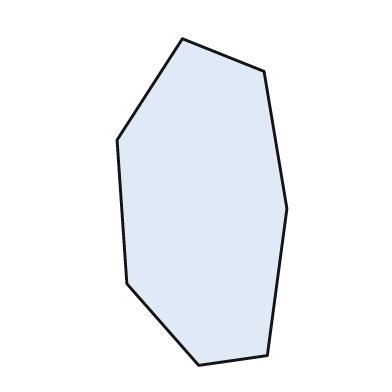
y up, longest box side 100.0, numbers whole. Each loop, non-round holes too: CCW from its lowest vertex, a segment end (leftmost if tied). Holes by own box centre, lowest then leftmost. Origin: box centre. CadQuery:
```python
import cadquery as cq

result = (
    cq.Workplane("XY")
    .moveTo(-1.0, -50.0)
    .lineTo(20.0, -47.0)
    .lineTo(26.0, -2.0)
    .lineTo(19.0, 40.0)
    .lineTo(-6.0, 50.0)
    .lineTo(-26.0, 19.0)
    .lineTo(-23.0, -25.0)
    .close()
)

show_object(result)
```